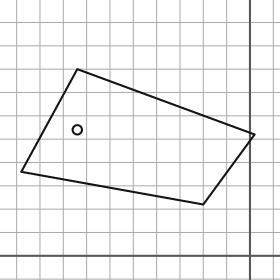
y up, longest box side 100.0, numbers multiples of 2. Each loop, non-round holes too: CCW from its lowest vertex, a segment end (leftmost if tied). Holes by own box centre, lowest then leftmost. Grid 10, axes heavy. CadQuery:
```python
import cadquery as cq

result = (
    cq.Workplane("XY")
    .moveTo(-20.0, 22.0)
    .lineTo(2.0, 52.0)
    .lineTo(-74.0, 80.0)
    .lineTo(-98.0, 36.0)
    .close()
    .moveTo(-74.0, 54.0)
    .circle(2.0)
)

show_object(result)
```